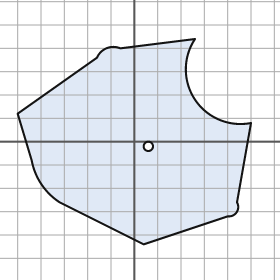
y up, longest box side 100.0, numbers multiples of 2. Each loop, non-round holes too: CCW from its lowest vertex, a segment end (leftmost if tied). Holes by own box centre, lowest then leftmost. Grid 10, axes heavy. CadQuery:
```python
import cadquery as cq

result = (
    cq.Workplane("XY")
    .moveTo(4.0, -44.0)
    .lineTo(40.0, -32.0)
    .threePointArc((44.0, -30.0), (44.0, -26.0))
    .lineTo(50.0, 8.0)
    .threePointArc((26.0, 18.0), (26.0, 44.0))
    .lineTo(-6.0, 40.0)
    .threePointArc((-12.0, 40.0), (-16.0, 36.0))
    .lineTo(-50.0, 12.0)
    .lineTo(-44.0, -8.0)
    .threePointArc((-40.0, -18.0), (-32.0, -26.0))
    .close()
    .moveTo(6.0, -2.0)
    .circle(2.0)
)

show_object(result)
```